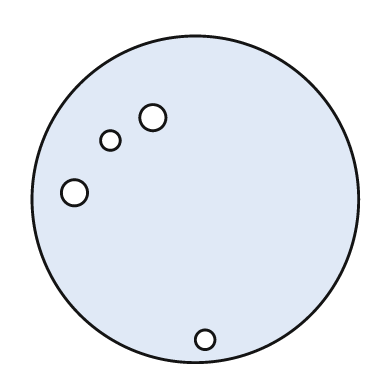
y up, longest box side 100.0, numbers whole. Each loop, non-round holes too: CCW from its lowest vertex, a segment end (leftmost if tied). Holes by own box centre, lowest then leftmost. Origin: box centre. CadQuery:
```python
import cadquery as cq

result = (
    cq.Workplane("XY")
    .moveTo(0.0, 0.0)
    .circle(50.0)
    .moveTo(3.0, -43.0)
    .circle(3.0)
    .moveTo(-37.0, 2.0)
    .circle(4.0)
    .moveTo(-26.0, 18.0)
    .circle(3.0)
    .moveTo(-13.0, 25.0)
    .circle(4.0)
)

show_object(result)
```